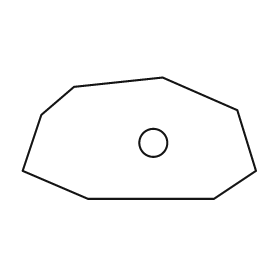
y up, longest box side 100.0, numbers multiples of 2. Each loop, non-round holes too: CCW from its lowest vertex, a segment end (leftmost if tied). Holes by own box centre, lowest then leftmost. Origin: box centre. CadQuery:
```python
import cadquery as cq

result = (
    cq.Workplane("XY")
    .moveTo(-22.0, -26.0)
    .lineTo(32.0, -26.0)
    .lineTo(50.0, -14.0)
    .lineTo(42.0, 12.0)
    .lineTo(10.0, 26.0)
    .lineTo(-28.0, 22.0)
    .lineTo(-42.0, 10.0)
    .lineTo(-50.0, -14.0)
    .close()
    .moveTo(6.0, -2.0)
    .circle(6.0)
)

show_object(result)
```